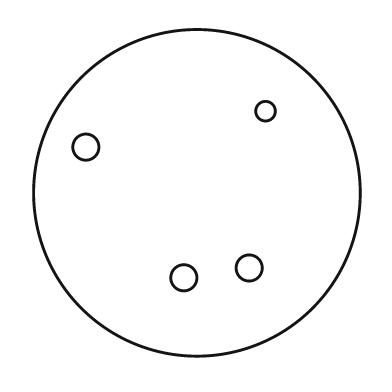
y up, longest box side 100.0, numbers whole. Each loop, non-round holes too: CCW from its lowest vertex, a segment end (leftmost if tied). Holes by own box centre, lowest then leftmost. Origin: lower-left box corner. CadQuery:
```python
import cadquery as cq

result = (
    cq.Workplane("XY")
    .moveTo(50.0, 50.0)
    .circle(50.0)
    .moveTo(46.0, 24.0)
    .circle(4.0)
    .moveTo(66.0, 27.0)
    .circle(4.0)
    .moveTo(16.0, 64.0)
    .circle(4.0)
    .moveTo(71.0, 75.0)
    .circle(3.0)
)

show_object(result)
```